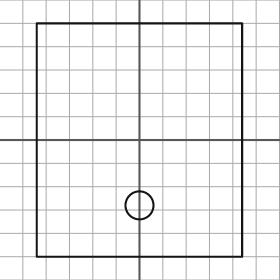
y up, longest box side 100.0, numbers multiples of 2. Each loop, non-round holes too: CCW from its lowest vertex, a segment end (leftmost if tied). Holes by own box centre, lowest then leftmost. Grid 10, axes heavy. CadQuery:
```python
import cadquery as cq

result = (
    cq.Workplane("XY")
    .moveTo(-44.0, -50.0)
    .lineTo(44.0, -50.0)
    .lineTo(44.0, 50.0)
    .lineTo(-44.0, 50.0)
    .close()
    .moveTo(0.0, -28.0)
    .circle(6.0)
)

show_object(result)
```